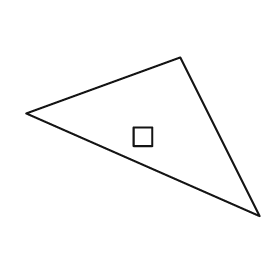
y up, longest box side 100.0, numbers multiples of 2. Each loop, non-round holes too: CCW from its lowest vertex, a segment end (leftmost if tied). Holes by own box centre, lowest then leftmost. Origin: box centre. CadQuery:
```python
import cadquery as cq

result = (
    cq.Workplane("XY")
    .moveTo(50.0, -34.0)
    .lineTo(16.0, 34.0)
    .lineTo(-50.0, 10.0)
    .close()
    .moveTo(-4.0, -4.0)
    .lineTo(4.0, -4.0)
    .lineTo(4.0, 4.0)
    .lineTo(-4.0, 4.0)
    .close()
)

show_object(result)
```